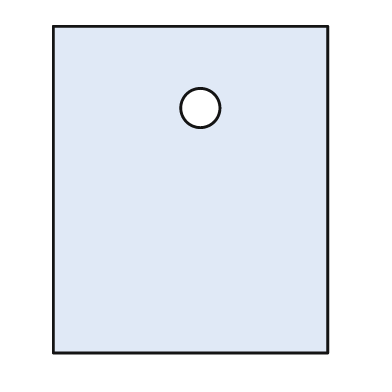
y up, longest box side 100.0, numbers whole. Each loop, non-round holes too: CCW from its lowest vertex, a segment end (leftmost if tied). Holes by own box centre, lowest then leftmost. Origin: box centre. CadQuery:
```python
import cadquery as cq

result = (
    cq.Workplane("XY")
    .moveTo(-42.0, -50.0)
    .lineTo(42.0, -50.0)
    .lineTo(42.0, 50.0)
    .lineTo(-42.0, 50.0)
    .close()
    .moveTo(3.0, 25.0)
    .circle(6.0)
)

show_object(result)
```